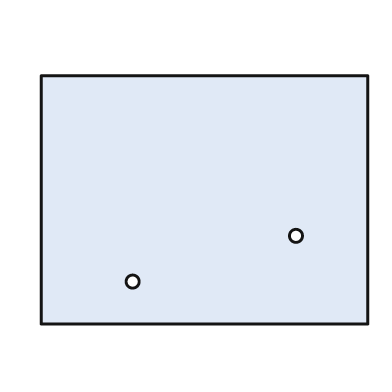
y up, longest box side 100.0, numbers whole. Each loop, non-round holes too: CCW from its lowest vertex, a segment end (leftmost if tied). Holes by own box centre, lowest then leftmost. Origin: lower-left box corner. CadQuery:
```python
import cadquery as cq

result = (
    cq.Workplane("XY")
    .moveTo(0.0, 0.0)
    .lineTo(100.0, 0.0)
    .lineTo(100.0, 76.0)
    .lineTo(0.0, 76.0)
    .close()
    .moveTo(28.0, 13.0)
    .circle(2.0)
    .moveTo(78.0, 27.0)
    .circle(2.0)
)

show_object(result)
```